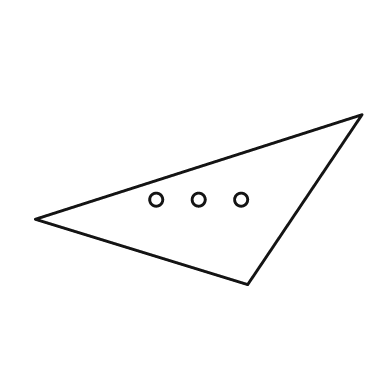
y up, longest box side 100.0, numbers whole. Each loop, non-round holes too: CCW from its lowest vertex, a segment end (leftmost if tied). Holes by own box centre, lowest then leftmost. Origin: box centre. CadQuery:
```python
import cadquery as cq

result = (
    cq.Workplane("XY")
    .moveTo(15.0, -26.0)
    .lineTo(50.0, 26.0)
    .lineTo(-50.0, -6.0)
    .close()
    .moveTo(-13.0, 0.0)
    .circle(2.0)
    .moveTo(0.0, 0.0)
    .circle(2.0)
    .moveTo(13.0, 0.0)
    .circle(2.0)
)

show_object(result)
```